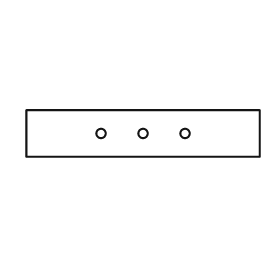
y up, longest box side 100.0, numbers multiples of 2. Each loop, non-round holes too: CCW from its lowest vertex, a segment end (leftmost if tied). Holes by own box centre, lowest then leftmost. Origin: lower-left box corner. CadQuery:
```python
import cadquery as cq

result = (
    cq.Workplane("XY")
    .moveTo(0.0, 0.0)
    .lineTo(100.0, 0.0)
    .lineTo(100.0, 20.0)
    .lineTo(0.0, 20.0)
    .close()
    .moveTo(32.0, 10.0)
    .circle(2.0)
    .moveTo(50.0, 10.0)
    .circle(2.0)
    .moveTo(68.0, 10.0)
    .circle(2.0)
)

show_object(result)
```